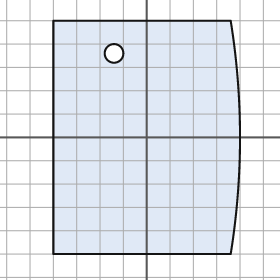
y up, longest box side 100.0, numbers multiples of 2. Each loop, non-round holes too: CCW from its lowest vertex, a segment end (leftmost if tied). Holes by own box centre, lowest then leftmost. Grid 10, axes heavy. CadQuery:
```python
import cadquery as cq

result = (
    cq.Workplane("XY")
    .moveTo(-40.0, -50.0)
    .lineTo(36.0, -50.0)
    .threePointArc((40.0, 0.0), (36.0, 50.0))
    .lineTo(-40.0, 50.0)
    .close()
    .moveTo(-14.0, 36.0)
    .circle(4.0)
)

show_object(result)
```